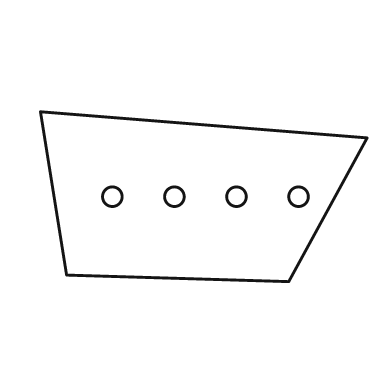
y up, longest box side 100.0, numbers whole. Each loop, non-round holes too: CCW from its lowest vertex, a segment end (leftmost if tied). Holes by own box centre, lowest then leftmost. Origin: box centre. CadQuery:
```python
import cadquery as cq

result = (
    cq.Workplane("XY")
    .moveTo(26.0, -26.0)
    .lineTo(50.0, 18.0)
    .lineTo(-50.0, 26.0)
    .lineTo(-42.0, -24.0)
    .close()
    .moveTo(-28.0, 0.0)
    .circle(3.0)
    .moveTo(-9.0, 0.0)
    .circle(3.0)
    .moveTo(10.0, 0.0)
    .circle(3.0)
    .moveTo(29.0, 0.0)
    .circle(3.0)
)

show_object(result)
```